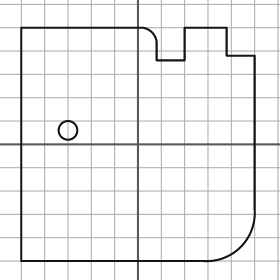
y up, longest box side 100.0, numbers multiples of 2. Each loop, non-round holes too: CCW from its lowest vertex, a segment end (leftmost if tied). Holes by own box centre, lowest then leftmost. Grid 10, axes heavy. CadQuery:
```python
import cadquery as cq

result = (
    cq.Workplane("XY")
    .moveTo(-50.0, -50.0)
    .lineTo(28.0, -50.0)
    .threePointArc((44.0, -44.0), (50.0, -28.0))
    .lineTo(50.0, 38.0)
    .lineTo(38.0, 38.0)
    .lineTo(38.0, 50.0)
    .lineTo(20.0, 50.0)
    .lineTo(20.0, 36.0)
    .lineTo(8.0, 36.0)
    .lineTo(8.0, 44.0)
    .threePointArc((6.0, 48.0), (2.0, 50.0))
    .lineTo(-50.0, 50.0)
    .close()
    .moveTo(-30.0, 6.0)
    .circle(4.0)
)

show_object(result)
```